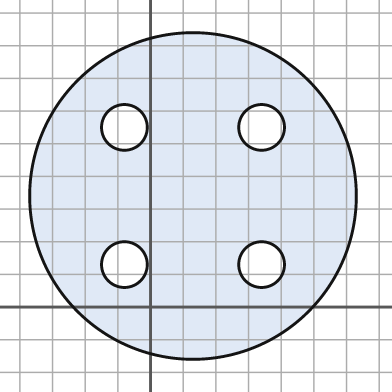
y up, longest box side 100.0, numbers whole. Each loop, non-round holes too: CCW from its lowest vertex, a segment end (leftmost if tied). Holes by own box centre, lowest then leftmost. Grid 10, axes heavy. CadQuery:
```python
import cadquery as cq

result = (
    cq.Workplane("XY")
    .moveTo(13.0, 34.0)
    .circle(50.0)
    .moveTo(-8.0, 13.0)
    .circle(7.0)
    .moveTo(34.0, 13.0)
    .circle(7.0)
    .moveTo(-8.0, 55.0)
    .circle(7.0)
    .moveTo(34.0, 55.0)
    .circle(7.0)
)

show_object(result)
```